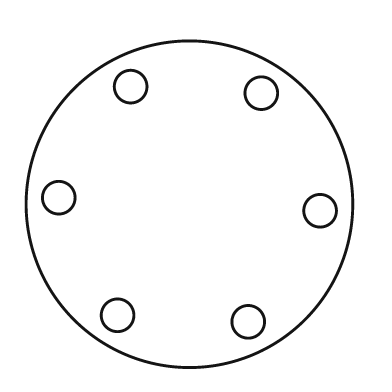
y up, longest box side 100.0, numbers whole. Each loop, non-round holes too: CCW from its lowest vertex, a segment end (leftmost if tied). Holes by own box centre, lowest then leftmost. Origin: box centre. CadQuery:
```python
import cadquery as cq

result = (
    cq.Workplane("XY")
    .moveTo(0.0, 0.0)
    .circle(50.0)
    .moveTo(18.0, -36.0)
    .circle(5.0)
    .moveTo(-22.0, -34.0)
    .circle(5.0)
    .moveTo(40.0, -2.0)
    .circle(5.0)
    .moveTo(-40.0, 2.0)
    .circle(5.0)
    .moveTo(22.0, 34.0)
    .circle(5.0)
    .moveTo(-18.0, 36.0)
    .circle(5.0)
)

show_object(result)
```